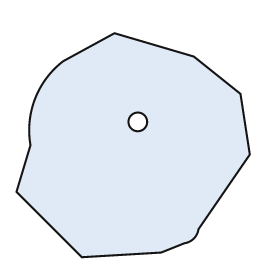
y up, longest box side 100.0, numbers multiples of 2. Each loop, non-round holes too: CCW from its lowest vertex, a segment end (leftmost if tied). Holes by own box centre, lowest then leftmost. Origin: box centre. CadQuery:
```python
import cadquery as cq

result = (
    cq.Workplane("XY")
    .moveTo(-22.0, -48.0)
    .lineTo(12.0, -46.0)
    .lineTo(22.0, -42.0)
    .threePointArc((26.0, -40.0), (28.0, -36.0))
    .lineTo(50.0, -4.0)
    .lineTo(46.0, 22.0)
    .lineTo(26.0, 38.0)
    .lineTo(-8.0, 48.0)
    .lineTo(-30.0, 36.0)
    .threePointArc((-42.0, 20.0), (-44.0, 0.0))
    .lineTo(-50.0, -20.0)
    .close()
    .moveTo(2.0, 10.0)
    .circle(4.0)
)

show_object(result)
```